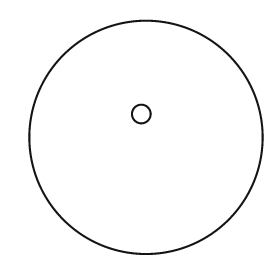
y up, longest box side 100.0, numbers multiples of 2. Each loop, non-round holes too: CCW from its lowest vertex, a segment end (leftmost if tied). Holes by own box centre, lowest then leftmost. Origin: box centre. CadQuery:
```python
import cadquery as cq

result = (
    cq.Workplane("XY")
    .moveTo(0.0, 0.0)
    .circle(50.0)
    .moveTo(-2.0, 10.0)
    .circle(4.0)
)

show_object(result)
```